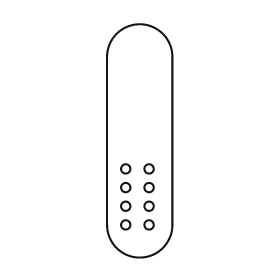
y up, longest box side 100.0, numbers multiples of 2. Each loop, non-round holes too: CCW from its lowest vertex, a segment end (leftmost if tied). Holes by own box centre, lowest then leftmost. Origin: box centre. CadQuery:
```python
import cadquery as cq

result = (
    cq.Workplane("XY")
    .moveTo(-14.0, -36.0)
    .threePointArc((0.0, -50.0), (14.0, -36.0))
    .lineTo(14.0, 36.0)
    .threePointArc((0.0, 50.0), (-14.0, 36.0))
    .close()
    .moveTo(-6.0, -36.0)
    .circle(2.0)
    .moveTo(4.0, -36.0)
    .circle(2.0)
    .moveTo(-6.0, -28.0)
    .circle(2.0)
    .moveTo(4.0, -28.0)
    .circle(2.0)
    .moveTo(-6.0, -20.0)
    .circle(2.0)
    .moveTo(4.0, -20.0)
    .circle(2.0)
    .moveTo(-6.0, -12.0)
    .circle(2.0)
    .moveTo(4.0, -12.0)
    .circle(2.0)
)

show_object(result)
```